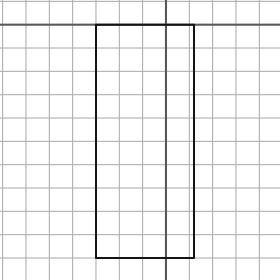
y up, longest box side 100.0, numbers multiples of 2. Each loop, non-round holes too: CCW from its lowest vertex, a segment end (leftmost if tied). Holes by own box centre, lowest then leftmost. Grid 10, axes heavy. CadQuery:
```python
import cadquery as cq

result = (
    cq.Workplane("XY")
    .moveTo(-30.0, -100.0)
    .lineTo(12.0, -100.0)
    .lineTo(12.0, 0.0)
    .lineTo(-30.0, 0.0)
    .close()
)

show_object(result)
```